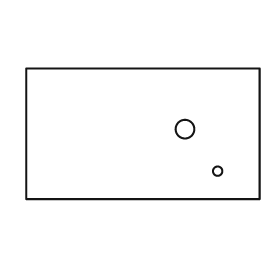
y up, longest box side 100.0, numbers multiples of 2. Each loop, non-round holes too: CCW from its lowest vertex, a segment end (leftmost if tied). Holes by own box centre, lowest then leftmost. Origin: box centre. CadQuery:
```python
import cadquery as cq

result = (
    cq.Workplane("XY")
    .moveTo(-50.0, -28.0)
    .lineTo(50.0, -28.0)
    .lineTo(50.0, 28.0)
    .lineTo(-50.0, 28.0)
    .close()
    .moveTo(32.0, -16.0)
    .circle(2.0)
    .moveTo(18.0, 2.0)
    .circle(4.0)
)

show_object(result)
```